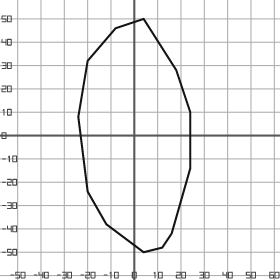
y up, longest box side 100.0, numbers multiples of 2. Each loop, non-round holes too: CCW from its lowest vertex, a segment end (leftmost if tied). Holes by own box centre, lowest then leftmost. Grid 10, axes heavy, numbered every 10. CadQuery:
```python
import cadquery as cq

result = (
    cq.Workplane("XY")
    .moveTo(4.0, -50.0)
    .lineTo(12.0, -48.0)
    .lineTo(16.0, -42.0)
    .lineTo(24.0, -14.0)
    .lineTo(24.0, 10.0)
    .lineTo(18.0, 28.0)
    .lineTo(4.0, 50.0)
    .lineTo(-8.0, 46.0)
    .lineTo(-20.0, 32.0)
    .lineTo(-24.0, 8.0)
    .lineTo(-20.0, -24.0)
    .lineTo(-12.0, -38.0)
    .close()
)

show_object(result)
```